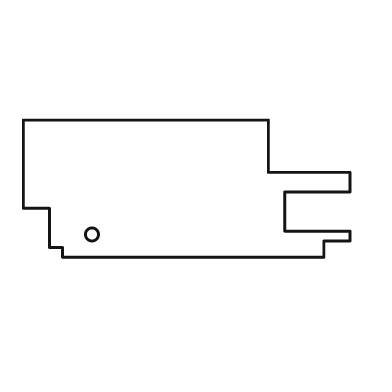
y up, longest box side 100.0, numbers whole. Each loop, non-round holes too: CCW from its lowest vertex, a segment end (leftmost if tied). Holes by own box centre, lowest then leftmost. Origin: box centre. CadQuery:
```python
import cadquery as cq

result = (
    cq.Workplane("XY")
    .moveTo(-38.0, -21.0)
    .lineTo(42.0, -21.0)
    .lineTo(42.0, -16.0)
    .lineTo(50.0, -16.0)
    .lineTo(50.0, -13.0)
    .lineTo(30.0, -13.0)
    .lineTo(30.0, -1.0)
    .lineTo(50.0, -1.0)
    .lineTo(50.0, 5.0)
    .lineTo(25.0, 5.0)
    .lineTo(25.0, 21.0)
    .lineTo(-50.0, 21.0)
    .lineTo(-50.0, -6.0)
    .lineTo(-42.0, -6.0)
    .lineTo(-42.0, -18.0)
    .lineTo(-38.0, -18.0)
    .close()
    .moveTo(-29.0, -14.0)
    .circle(2.0)
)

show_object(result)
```